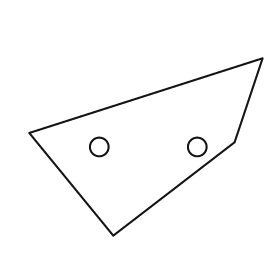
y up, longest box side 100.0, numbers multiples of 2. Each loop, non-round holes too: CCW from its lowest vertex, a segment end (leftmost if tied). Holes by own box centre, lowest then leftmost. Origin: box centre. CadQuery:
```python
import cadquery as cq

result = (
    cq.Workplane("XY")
    .moveTo(-14.0, -38.0)
    .lineTo(38.0, 2.0)
    .lineTo(50.0, 38.0)
    .lineTo(-50.0, 6.0)
    .close()
    .moveTo(-20.0, 0.0)
    .circle(4.0)
    .moveTo(22.0, 0.0)
    .circle(4.0)
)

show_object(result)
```